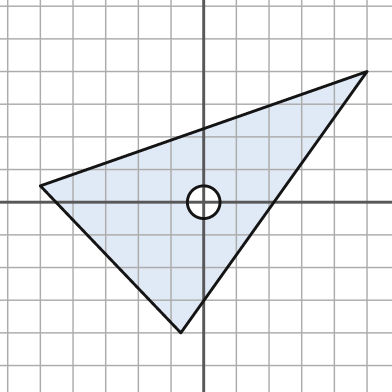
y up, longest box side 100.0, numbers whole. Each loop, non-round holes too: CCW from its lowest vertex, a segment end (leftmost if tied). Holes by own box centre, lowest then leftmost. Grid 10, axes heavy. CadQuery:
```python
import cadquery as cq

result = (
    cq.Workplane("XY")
    .moveTo(-7.0, -40.0)
    .lineTo(50.0, 40.0)
    .lineTo(-50.0, 5.0)
    .close()
    .moveTo(0.0, 0.0)
    .circle(5.0)
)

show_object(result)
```